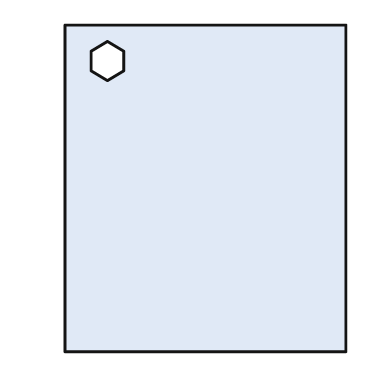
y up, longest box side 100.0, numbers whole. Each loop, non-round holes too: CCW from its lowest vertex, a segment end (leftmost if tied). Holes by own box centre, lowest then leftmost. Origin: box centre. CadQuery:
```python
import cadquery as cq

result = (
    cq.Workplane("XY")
    .moveTo(-43.0, -50.0)
    .lineTo(43.0, -50.0)
    .lineTo(43.0, 50.0)
    .lineTo(-43.0, 50.0)
    .close()
    .moveTo(-30.0, 33.0)
    .lineTo(-25.0, 36.0)
    .lineTo(-25.0, 42.0)
    .lineTo(-30.0, 45.0)
    .lineTo(-35.0, 42.0)
    .lineTo(-35.0, 36.0)
    .close()
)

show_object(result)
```